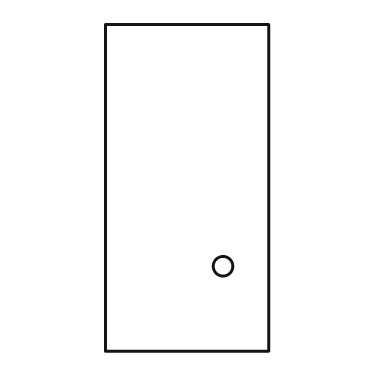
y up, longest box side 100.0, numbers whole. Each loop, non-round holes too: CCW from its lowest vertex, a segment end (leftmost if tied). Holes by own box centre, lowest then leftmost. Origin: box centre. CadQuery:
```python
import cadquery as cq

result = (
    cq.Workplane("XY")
    .moveTo(-25.0, -50.0)
    .lineTo(25.0, -50.0)
    .lineTo(25.0, 50.0)
    .lineTo(-25.0, 50.0)
    .close()
    .moveTo(11.0, -24.0)
    .circle(3.0)
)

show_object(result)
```